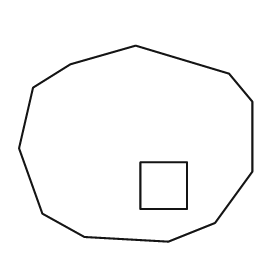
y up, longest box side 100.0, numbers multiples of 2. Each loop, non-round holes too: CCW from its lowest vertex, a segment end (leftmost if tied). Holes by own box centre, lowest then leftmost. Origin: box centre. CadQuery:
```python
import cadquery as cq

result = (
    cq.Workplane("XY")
    .moveTo(14.0, -42.0)
    .lineTo(34.0, -34.0)
    .lineTo(50.0, -12.0)
    .lineTo(50.0, 18.0)
    .lineTo(40.0, 30.0)
    .lineTo(0.0, 42.0)
    .lineTo(-28.0, 34.0)
    .lineTo(-44.0, 24.0)
    .lineTo(-50.0, -2.0)
    .lineTo(-40.0, -30.0)
    .lineTo(-22.0, -40.0)
    .close()
    .moveTo(2.0, -28.0)
    .lineTo(22.0, -28.0)
    .lineTo(22.0, -8.0)
    .lineTo(2.0, -8.0)
    .close()
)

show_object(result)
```